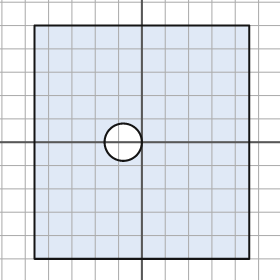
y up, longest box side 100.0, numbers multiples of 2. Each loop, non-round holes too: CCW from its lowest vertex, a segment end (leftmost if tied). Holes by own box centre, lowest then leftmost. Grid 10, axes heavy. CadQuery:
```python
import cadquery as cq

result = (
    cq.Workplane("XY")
    .moveTo(-46.0, -50.0)
    .lineTo(46.0, -50.0)
    .lineTo(46.0, 50.0)
    .lineTo(-46.0, 50.0)
    .close()
    .moveTo(-8.0, 0.0)
    .circle(8.0)
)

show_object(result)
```